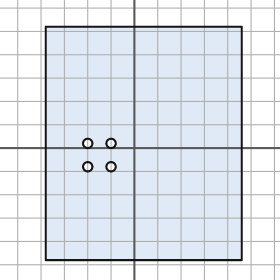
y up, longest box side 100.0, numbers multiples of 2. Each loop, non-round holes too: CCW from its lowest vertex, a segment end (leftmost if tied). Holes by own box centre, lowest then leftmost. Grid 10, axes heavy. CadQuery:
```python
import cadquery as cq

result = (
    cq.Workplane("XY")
    .moveTo(-38.0, -48.0)
    .lineTo(46.0, -48.0)
    .lineTo(46.0, 52.0)
    .lineTo(-38.0, 52.0)
    .close()
    .moveTo(-20.0, -8.0)
    .circle(2.0)
    .moveTo(-10.0, -8.0)
    .circle(2.0)
    .moveTo(-20.0, 2.0)
    .circle(2.0)
    .moveTo(-10.0, 2.0)
    .circle(2.0)
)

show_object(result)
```